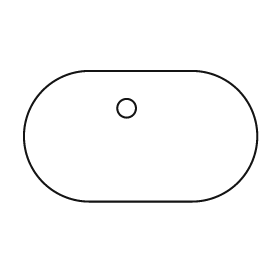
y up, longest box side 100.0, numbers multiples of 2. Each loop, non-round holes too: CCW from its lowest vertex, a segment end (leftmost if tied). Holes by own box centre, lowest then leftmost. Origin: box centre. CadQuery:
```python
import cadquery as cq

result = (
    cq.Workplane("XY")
    .moveTo(-22.0, -28.0)
    .lineTo(22.0, -28.0)
    .threePointArc((50.0, 0.0), (22.0, 28.0))
    .lineTo(-22.0, 28.0)
    .threePointArc((-50.0, 0.0), (-22.0, -28.0))
    .close()
    .moveTo(-6.0, 12.0)
    .circle(4.0)
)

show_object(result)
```